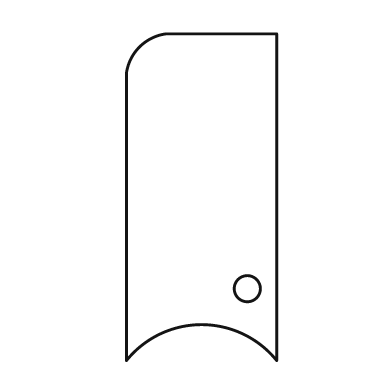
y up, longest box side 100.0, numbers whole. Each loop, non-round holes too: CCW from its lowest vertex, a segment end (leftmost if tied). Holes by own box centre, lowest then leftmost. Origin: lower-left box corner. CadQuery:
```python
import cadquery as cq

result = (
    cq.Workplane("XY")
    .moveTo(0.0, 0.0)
    .threePointArc((23.0, 11.0), (46.0, 0.0))
    .lineTo(46.0, 100.0)
    .lineTo(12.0, 100.0)
    .threePointArc((4.0, 96.0), (0.0, 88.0))
    .close()
    .moveTo(37.0, 22.0)
    .circle(4.0)
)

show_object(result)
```